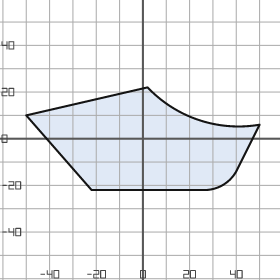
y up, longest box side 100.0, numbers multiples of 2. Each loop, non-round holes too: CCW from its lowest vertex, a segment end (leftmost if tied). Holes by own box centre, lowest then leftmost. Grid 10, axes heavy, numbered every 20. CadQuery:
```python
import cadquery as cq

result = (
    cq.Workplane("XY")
    .moveTo(-22.0, -22.0)
    .lineTo(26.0, -22.0)
    .threePointArc((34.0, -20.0), (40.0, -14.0))
    .lineTo(50.0, 6.0)
    .threePointArc((24.0, 8.0), (2.0, 22.0))
    .lineTo(-50.0, 10.0)
    .close()
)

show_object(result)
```